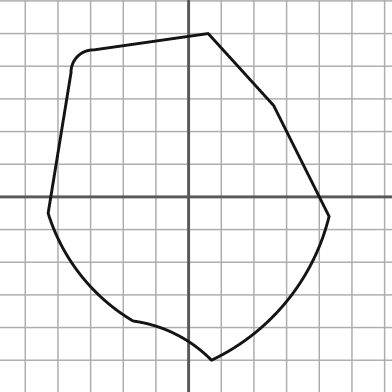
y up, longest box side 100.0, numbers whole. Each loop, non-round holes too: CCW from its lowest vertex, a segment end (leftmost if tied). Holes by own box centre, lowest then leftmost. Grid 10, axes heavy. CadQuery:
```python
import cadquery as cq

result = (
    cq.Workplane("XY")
    .moveTo(7.0, -50.0)
    .threePointArc((30.0, -32.0), (43.0, -6.0))
    .lineTo(26.0, 28.0)
    .lineTo(6.0, 50.0)
    .lineTo(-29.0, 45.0)
    .threePointArc((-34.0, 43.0), (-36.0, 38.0))
    .lineTo(-43.0, -5.0)
    .threePointArc((-33.0, -24.0), (-17.0, -38.0))
    .threePointArc((-4.0, -42.0), (7.0, -50.0))
    .close()
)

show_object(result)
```